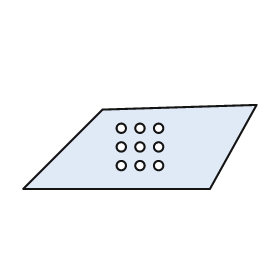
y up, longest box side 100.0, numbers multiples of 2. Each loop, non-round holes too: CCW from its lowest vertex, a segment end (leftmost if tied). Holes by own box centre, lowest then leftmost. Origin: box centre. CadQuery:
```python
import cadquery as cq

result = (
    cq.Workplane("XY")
    .moveTo(-50.0, -18.0)
    .lineTo(30.0, -18.0)
    .lineTo(50.0, 18.0)
    .lineTo(-16.0, 16.0)
    .close()
    .moveTo(-8.0, -8.0)
    .circle(2.0)
    .moveTo(0.0, -8.0)
    .circle(2.0)
    .moveTo(8.0, -8.0)
    .circle(2.0)
    .moveTo(-8.0, 0.0)
    .circle(2.0)
    .moveTo(0.0, 0.0)
    .circle(2.0)
    .moveTo(8.0, 0.0)
    .circle(2.0)
    .moveTo(-8.0, 8.0)
    .circle(2.0)
    .moveTo(0.0, 8.0)
    .circle(2.0)
    .moveTo(8.0, 8.0)
    .circle(2.0)
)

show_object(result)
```